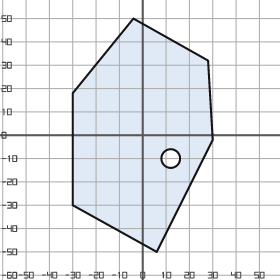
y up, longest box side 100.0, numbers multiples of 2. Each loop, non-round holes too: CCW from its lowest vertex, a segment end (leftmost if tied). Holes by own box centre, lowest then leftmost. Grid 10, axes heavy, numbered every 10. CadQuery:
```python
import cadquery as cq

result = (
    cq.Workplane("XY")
    .moveTo(6.0, -50.0)
    .lineTo(30.0, -2.0)
    .lineTo(28.0, 32.0)
    .lineTo(-4.0, 50.0)
    .lineTo(-30.0, 18.0)
    .lineTo(-30.0, -30.0)
    .close()
    .moveTo(12.0, -10.0)
    .circle(4.0)
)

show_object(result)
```